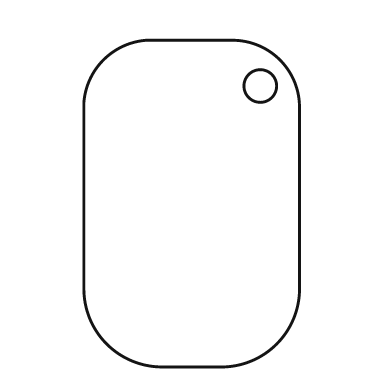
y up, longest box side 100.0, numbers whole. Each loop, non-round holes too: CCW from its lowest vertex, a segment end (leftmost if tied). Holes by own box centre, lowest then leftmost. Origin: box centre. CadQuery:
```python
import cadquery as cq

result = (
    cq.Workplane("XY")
    .moveTo(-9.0, -50.0)
    .lineTo(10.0, -50.0)
    .threePointArc((26.0, -43.0), (33.0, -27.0))
    .lineTo(33.0, 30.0)
    .threePointArc((27.0, 44.0), (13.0, 50.0))
    .lineTo(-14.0, 50.0)
    .threePointArc((-27.0, 44.0), (-33.0, 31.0))
    .lineTo(-33.0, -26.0)
    .threePointArc((-26.0, -43.0), (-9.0, -50.0))
    .close()
    .moveTo(21.0, 36.0)
    .circle(5.0)
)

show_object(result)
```